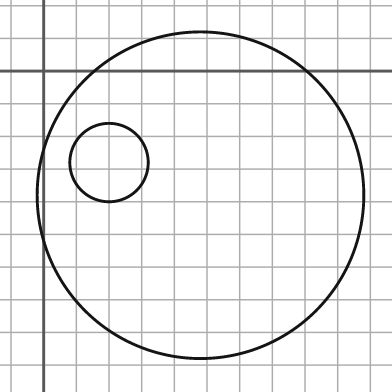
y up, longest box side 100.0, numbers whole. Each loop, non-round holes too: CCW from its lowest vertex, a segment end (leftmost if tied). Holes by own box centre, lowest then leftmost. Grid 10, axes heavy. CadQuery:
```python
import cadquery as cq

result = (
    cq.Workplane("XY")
    .moveTo(48.0, -38.0)
    .circle(50.0)
    .moveTo(20.0, -28.0)
    .circle(12.0)
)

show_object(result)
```